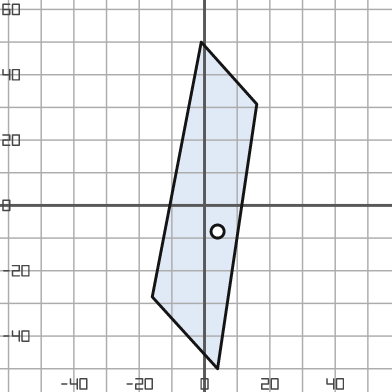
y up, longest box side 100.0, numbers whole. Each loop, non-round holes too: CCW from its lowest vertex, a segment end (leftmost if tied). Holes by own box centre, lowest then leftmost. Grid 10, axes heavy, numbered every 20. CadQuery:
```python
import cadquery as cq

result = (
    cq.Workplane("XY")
    .moveTo(4.0, -50.0)
    .lineTo(16.0, 31.0)
    .lineTo(-1.0, 50.0)
    .lineTo(-16.0, -28.0)
    .close()
    .moveTo(4.0, -8.0)
    .circle(2.0)
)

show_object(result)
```